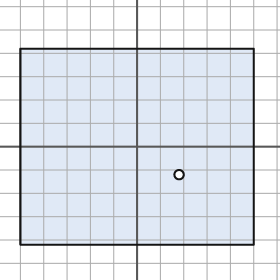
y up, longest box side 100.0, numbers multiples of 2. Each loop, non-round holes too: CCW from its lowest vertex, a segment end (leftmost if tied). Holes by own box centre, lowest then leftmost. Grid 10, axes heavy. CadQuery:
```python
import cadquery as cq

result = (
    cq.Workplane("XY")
    .moveTo(-50.0, -42.0)
    .lineTo(50.0, -42.0)
    .lineTo(50.0, 42.0)
    .lineTo(-50.0, 42.0)
    .close()
    .moveTo(18.0, -12.0)
    .circle(2.0)
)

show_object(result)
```